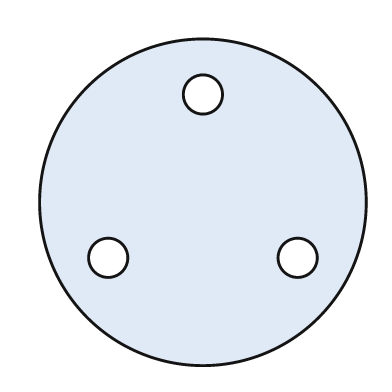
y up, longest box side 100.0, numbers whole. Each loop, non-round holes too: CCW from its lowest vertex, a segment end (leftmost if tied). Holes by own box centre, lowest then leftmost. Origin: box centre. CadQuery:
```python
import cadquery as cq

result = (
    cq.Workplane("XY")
    .moveTo(0.0, 0.0)
    .circle(50.0)
    .moveTo(-29.0, -17.0)
    .circle(6.0)
    .moveTo(29.0, -17.0)
    .circle(6.0)
    .moveTo(0.0, 33.0)
    .circle(6.0)
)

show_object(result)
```